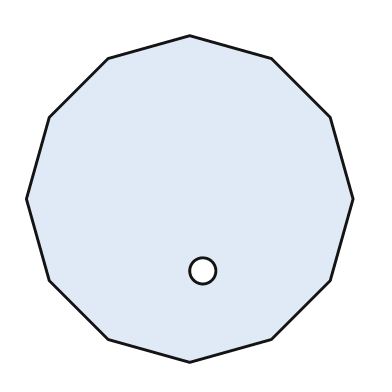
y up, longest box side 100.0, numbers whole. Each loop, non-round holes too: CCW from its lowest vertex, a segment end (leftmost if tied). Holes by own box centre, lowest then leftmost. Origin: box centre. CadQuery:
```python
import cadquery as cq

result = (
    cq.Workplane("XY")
    .moveTo(0.0, -50.0)
    .lineTo(25.0, -43.0)
    .lineTo(43.0, -25.0)
    .lineTo(50.0, 0.0)
    .lineTo(43.0, 25.0)
    .lineTo(25.0, 43.0)
    .lineTo(0.0, 50.0)
    .lineTo(-25.0, 43.0)
    .lineTo(-43.0, 25.0)
    .lineTo(-50.0, 0.0)
    .lineTo(-43.0, -25.0)
    .lineTo(-25.0, -43.0)
    .close()
    .moveTo(4.0, -22.0)
    .circle(4.0)
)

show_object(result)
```